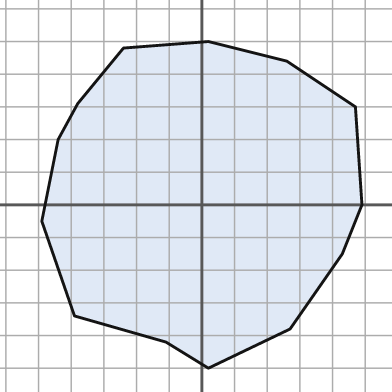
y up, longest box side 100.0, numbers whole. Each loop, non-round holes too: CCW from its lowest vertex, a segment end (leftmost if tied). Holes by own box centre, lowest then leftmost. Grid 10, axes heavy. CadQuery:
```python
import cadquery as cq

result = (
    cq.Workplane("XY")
    .moveTo(2.0, -50.0)
    .lineTo(27.0, -38.0)
    .lineTo(43.0, -15.0)
    .lineTo(49.0, 0.0)
    .lineTo(47.0, 30.0)
    .lineTo(26.0, 44.0)
    .lineTo(2.0, 50.0)
    .lineTo(-24.0, 48.0)
    .lineTo(-38.0, 31.0)
    .lineTo(-44.0, 20.0)
    .lineTo(-49.0, -5.0)
    .lineTo(-39.0, -34.0)
    .lineTo(-11.0, -42.0)
    .close()
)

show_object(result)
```